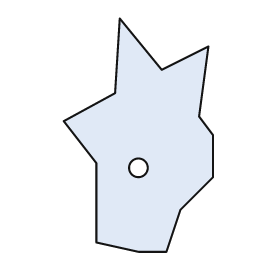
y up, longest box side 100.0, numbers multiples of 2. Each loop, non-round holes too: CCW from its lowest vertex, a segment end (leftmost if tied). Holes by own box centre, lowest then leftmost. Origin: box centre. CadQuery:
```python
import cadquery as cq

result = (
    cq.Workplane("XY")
    .moveTo(0.0, -50.0)
    .lineTo(12.0, -50.0)
    .lineTo(18.0, -32.0)
    .lineTo(32.0, -18.0)
    .lineTo(32.0, 0.0)
    .lineTo(26.0, 8.0)
    .lineTo(30.0, 38.0)
    .lineTo(10.0, 28.0)
    .lineTo(-8.0, 50.0)
    .lineTo(-10.0, 18.0)
    .lineTo(-32.0, 6.0)
    .lineTo(-18.0, -12.0)
    .lineTo(-18.0, -46.0)
    .close()
    .moveTo(0.0, -14.0)
    .circle(4.0)
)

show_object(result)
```